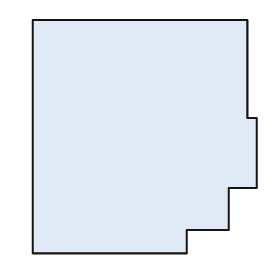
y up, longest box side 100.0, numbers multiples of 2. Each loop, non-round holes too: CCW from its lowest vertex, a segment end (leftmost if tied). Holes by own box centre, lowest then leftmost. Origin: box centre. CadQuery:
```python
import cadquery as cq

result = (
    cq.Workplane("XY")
    .moveTo(-48.0, -50.0)
    .lineTo(18.0, -50.0)
    .lineTo(18.0, -40.0)
    .lineTo(36.0, -40.0)
    .lineTo(36.0, -22.0)
    .lineTo(48.0, -22.0)
    .lineTo(48.0, 8.0)
    .lineTo(44.0, 8.0)
    .lineTo(44.0, 50.0)
    .lineTo(-48.0, 50.0)
    .close()
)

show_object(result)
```